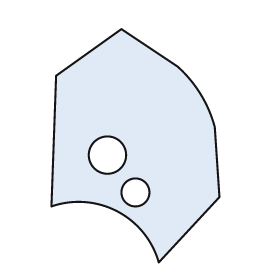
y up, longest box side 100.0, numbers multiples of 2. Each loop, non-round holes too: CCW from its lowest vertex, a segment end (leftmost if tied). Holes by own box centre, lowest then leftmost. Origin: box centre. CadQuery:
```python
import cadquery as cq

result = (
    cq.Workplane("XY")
    .moveTo(10.0, -50.0)
    .lineTo(36.0, -22.0)
    .lineTo(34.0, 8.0)
    .threePointArc((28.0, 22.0), (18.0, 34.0))
    .lineTo(-6.0, 50.0)
    .lineTo(-34.0, 30.0)
    .lineTo(-36.0, -26.0)
    .threePointArc((-8.0, -28.0), (10.0, -50.0))
    .close()
    .moveTo(0.0, -20.0)
    .circle(6.0)
    .moveTo(-12.0, -4.0)
    .circle(8.0)
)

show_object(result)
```